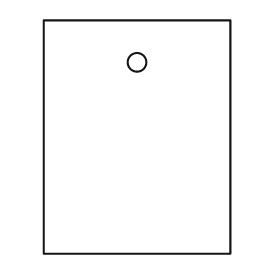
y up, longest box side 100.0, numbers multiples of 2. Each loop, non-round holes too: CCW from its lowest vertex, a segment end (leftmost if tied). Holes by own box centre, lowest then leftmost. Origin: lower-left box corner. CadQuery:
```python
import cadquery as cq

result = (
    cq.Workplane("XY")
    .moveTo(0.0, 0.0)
    .lineTo(80.0, 0.0)
    .lineTo(80.0, 100.0)
    .lineTo(0.0, 100.0)
    .close()
    .moveTo(40.0, 82.0)
    .circle(4.0)
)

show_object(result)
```